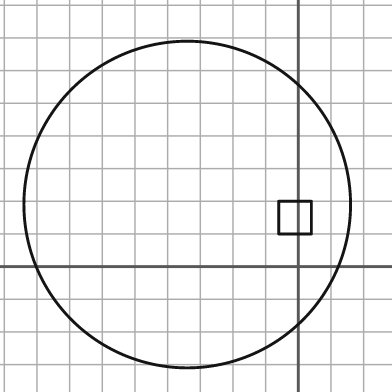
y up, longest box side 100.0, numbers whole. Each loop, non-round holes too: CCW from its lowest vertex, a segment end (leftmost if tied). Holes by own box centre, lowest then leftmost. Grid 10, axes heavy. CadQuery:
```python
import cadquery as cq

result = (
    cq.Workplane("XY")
    .moveTo(-34.0, 19.0)
    .circle(50.0)
    .moveTo(-6.0, 10.0)
    .lineTo(4.0, 10.0)
    .lineTo(4.0, 20.0)
    .lineTo(-6.0, 20.0)
    .close()
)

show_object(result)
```